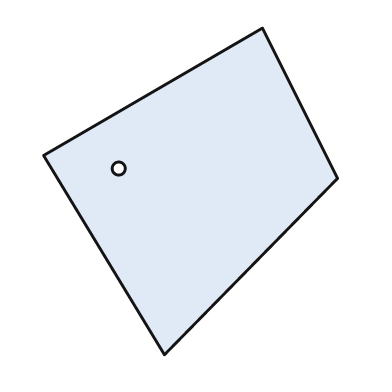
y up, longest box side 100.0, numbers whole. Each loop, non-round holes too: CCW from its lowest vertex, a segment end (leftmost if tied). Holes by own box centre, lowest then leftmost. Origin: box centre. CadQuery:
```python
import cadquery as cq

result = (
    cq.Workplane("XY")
    .moveTo(-8.0, -50.0)
    .lineTo(45.0, 4.0)
    .lineTo(22.0, 50.0)
    .lineTo(-45.0, 11.0)
    .close()
    .moveTo(-22.0, 7.0)
    .circle(2.0)
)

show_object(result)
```